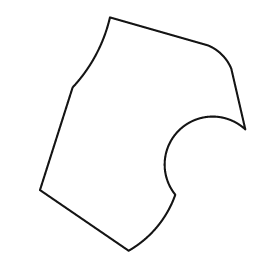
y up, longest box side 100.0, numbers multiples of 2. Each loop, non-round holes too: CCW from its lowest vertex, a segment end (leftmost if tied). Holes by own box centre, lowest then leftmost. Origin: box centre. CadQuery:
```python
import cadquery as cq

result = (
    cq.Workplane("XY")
    .moveTo(-6.0, -50.0)
    .threePointArc((6.0, -40.0), (14.0, -26.0))
    .threePointArc((16.0, 2.0), (44.0, 2.0))
    .lineTo(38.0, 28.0)
    .threePointArc((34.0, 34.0), (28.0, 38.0))
    .lineTo(-14.0, 50.0)
    .threePointArc((-20.0, 34.0), (-30.0, 20.0))
    .lineTo(-44.0, -24.0)
    .close()
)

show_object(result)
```